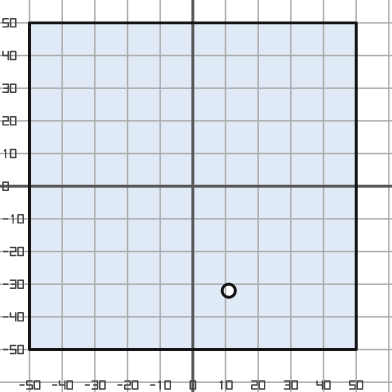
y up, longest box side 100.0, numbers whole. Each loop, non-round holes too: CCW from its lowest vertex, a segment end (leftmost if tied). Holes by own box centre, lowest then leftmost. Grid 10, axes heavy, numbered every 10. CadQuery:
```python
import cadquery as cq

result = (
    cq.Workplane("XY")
    .moveTo(-50.0, -50.0)
    .lineTo(50.0, -50.0)
    .lineTo(50.0, 50.0)
    .lineTo(-50.0, 50.0)
    .close()
    .moveTo(11.0, -32.0)
    .circle(2.0)
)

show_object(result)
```